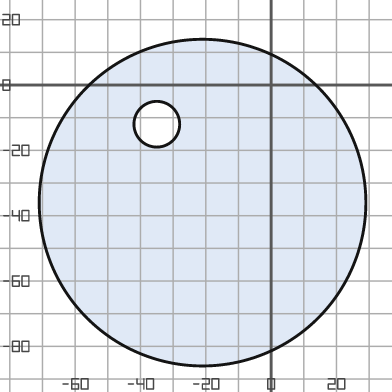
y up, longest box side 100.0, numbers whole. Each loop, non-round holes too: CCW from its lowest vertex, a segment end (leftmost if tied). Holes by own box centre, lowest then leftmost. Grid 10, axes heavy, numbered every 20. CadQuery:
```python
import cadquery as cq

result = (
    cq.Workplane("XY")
    .moveTo(-21.0, -36.0)
    .circle(50.0)
    .moveTo(-35.0, -12.0)
    .circle(7.0)
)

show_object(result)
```